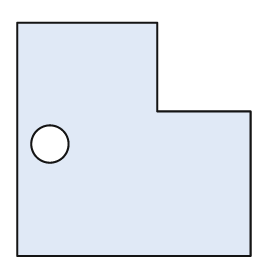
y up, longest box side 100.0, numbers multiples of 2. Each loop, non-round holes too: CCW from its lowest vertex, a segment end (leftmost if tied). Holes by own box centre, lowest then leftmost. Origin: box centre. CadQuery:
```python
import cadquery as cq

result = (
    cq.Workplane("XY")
    .moveTo(-50.0, -50.0)
    .lineTo(50.0, -50.0)
    .lineTo(50.0, 12.0)
    .lineTo(10.0, 12.0)
    .lineTo(10.0, 50.0)
    .lineTo(-50.0, 50.0)
    .close()
    .moveTo(-36.0, -2.0)
    .circle(8.0)
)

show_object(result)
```